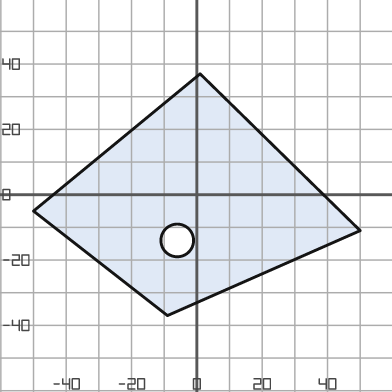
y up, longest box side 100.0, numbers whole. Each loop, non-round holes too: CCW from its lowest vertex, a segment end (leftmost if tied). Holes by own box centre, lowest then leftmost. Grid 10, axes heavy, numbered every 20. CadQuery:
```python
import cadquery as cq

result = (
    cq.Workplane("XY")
    .moveTo(-9.0, -37.0)
    .lineTo(50.0, -11.0)
    .lineTo(1.0, 37.0)
    .lineTo(-50.0, -5.0)
    .close()
    .moveTo(-6.0, -14.0)
    .circle(5.0)
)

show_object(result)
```